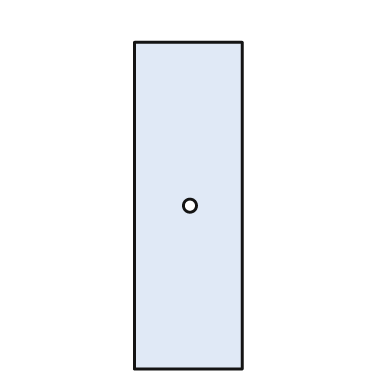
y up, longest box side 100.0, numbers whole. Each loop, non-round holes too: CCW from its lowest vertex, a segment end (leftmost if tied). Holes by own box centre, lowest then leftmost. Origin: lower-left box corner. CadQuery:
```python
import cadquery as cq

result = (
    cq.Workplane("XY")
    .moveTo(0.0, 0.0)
    .lineTo(33.0, 0.0)
    .lineTo(33.0, 100.0)
    .lineTo(0.0, 100.0)
    .close()
    .moveTo(17.0, 50.0)
    .circle(2.0)
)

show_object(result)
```